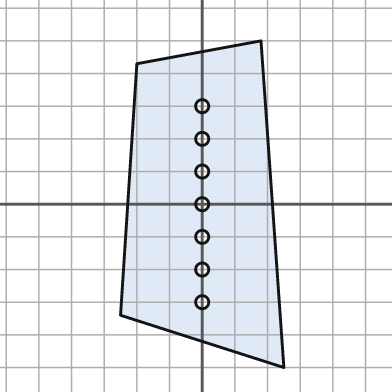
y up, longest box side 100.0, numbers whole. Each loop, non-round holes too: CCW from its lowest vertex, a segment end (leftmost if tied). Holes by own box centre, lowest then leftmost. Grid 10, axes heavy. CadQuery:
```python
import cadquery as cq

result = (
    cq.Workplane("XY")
    .moveTo(25.0, -50.0)
    .lineTo(18.0, 50.0)
    .lineTo(-20.0, 43.0)
    .lineTo(-25.0, -34.0)
    .close()
    .moveTo(0.0, -30.0)
    .circle(2.0)
    .moveTo(0.0, -20.0)
    .circle(2.0)
    .moveTo(0.0, -10.0)
    .circle(2.0)
    .moveTo(0.0, 0.0)
    .circle(2.0)
    .moveTo(0.0, 10.0)
    .circle(2.0)
    .moveTo(0.0, 20.0)
    .circle(2.0)
    .moveTo(0.0, 30.0)
    .circle(2.0)
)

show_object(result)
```